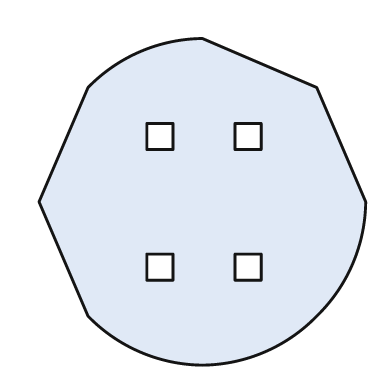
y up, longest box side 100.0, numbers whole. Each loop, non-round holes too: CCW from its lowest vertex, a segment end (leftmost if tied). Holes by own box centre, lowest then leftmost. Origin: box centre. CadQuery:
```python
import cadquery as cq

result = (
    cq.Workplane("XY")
    .moveTo(0.0, -50.0)
    .threePointArc((19.0, -46.0), (35.0, -35.0))
    .threePointArc((46.0, -19.0), (50.0, 0.0))
    .lineTo(35.0, 35.0)
    .lineTo(0.0, 50.0)
    .threePointArc((-19.0, 46.0), (-35.0, 35.0))
    .lineTo(-50.0, 0.0)
    .lineTo(-35.0, -35.0)
    .threePointArc((-19.0, -46.0), (0.0, -50.0))
    .close()
    .moveTo(-17.0, -24.0)
    .lineTo(-9.0, -24.0)
    .lineTo(-9.0, -16.0)
    .lineTo(-17.0, -16.0)
    .close()
    .moveTo(10.0, -24.0)
    .lineTo(18.0, -24.0)
    .lineTo(18.0, -16.0)
    .lineTo(10.0, -16.0)
    .close()
    .moveTo(-17.0, 16.0)
    .lineTo(-9.0, 16.0)
    .lineTo(-9.0, 24.0)
    .lineTo(-17.0, 24.0)
    .close()
    .moveTo(10.0, 16.0)
    .lineTo(18.0, 16.0)
    .lineTo(18.0, 24.0)
    .lineTo(10.0, 24.0)
    .close()
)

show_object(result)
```